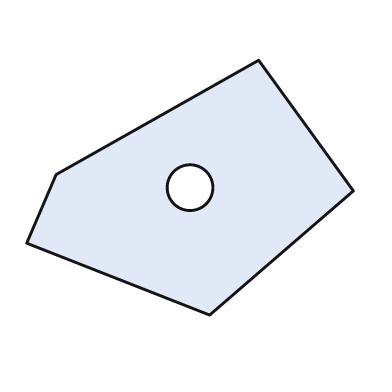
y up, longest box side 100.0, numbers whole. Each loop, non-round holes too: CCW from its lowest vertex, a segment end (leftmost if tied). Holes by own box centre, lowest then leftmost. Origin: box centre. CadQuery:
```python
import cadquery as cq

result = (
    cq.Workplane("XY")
    .moveTo(6.0, -39.0)
    .lineTo(50.0, -1.0)
    .lineTo(21.0, 39.0)
    .lineTo(-41.0, 4.0)
    .lineTo(-50.0, -17.0)
    .close()
    .moveTo(0.0, 0.0)
    .circle(7.0)
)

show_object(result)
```